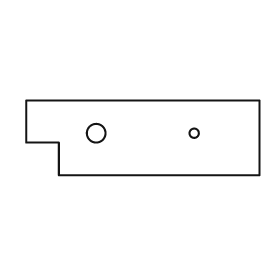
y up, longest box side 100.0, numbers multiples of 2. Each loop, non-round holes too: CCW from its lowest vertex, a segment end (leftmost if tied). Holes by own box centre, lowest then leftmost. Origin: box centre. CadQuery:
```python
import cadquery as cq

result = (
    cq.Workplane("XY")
    .moveTo(-36.0, -16.0)
    .lineTo(50.0, -16.0)
    .lineTo(50.0, 16.0)
    .lineTo(-50.0, 16.0)
    .lineTo(-50.0, -2.0)
    .lineTo(-36.0, -2.0)
    .close()
    .moveTo(-20.0, 2.0)
    .circle(4.0)
    .moveTo(22.0, 2.0)
    .circle(2.0)
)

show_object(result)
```